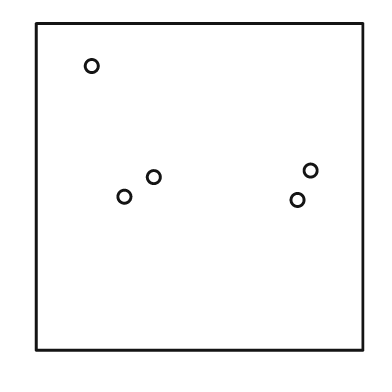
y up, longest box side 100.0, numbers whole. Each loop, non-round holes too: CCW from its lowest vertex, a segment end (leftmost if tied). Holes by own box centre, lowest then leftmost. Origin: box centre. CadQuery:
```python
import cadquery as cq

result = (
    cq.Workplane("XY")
    .moveTo(-50.0, -50.0)
    .lineTo(50.0, -50.0)
    .lineTo(50.0, 50.0)
    .lineTo(-50.0, 50.0)
    .close()
    .moveTo(30.0, -4.0)
    .circle(2.0)
    .moveTo(-23.0, -3.0)
    .circle(2.0)
    .moveTo(-14.0, 3.0)
    .circle(2.0)
    .moveTo(34.0, 5.0)
    .circle(2.0)
    .moveTo(-33.0, 37.0)
    .circle(2.0)
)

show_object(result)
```